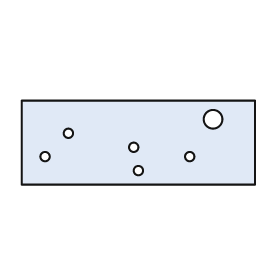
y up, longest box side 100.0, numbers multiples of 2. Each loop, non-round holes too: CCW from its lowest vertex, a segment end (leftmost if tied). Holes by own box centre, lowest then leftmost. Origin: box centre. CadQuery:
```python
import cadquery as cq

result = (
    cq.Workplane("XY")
    .moveTo(-50.0, -18.0)
    .lineTo(50.0, -18.0)
    .lineTo(50.0, 18.0)
    .lineTo(-50.0, 18.0)
    .close()
    .moveTo(0.0, -12.0)
    .circle(2.0)
    .moveTo(-40.0, -6.0)
    .circle(2.0)
    .moveTo(22.0, -6.0)
    .circle(2.0)
    .moveTo(-2.0, -2.0)
    .circle(2.0)
    .moveTo(-30.0, 4.0)
    .circle(2.0)
    .moveTo(32.0, 10.0)
    .circle(4.0)
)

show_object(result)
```